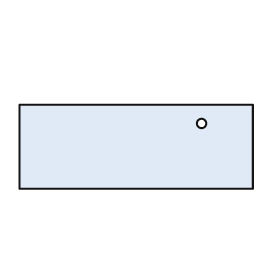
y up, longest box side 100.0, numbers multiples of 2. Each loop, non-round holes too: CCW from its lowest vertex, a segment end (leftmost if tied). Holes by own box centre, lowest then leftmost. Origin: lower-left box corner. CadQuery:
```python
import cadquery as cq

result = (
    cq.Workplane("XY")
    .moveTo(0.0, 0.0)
    .lineTo(100.0, 0.0)
    .lineTo(100.0, 36.0)
    .lineTo(0.0, 36.0)
    .close()
    .moveTo(78.0, 28.0)
    .circle(2.0)
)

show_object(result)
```